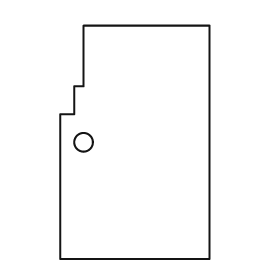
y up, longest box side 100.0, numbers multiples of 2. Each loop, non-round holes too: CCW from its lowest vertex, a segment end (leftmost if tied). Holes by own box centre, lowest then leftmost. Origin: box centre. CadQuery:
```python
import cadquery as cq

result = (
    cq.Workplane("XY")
    .moveTo(-32.0, -50.0)
    .lineTo(32.0, -50.0)
    .lineTo(32.0, 50.0)
    .lineTo(-22.0, 50.0)
    .lineTo(-22.0, 24.0)
    .lineTo(-26.0, 24.0)
    .lineTo(-26.0, 12.0)
    .lineTo(-32.0, 12.0)
    .close()
    .moveTo(-22.0, 0.0)
    .circle(4.0)
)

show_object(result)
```